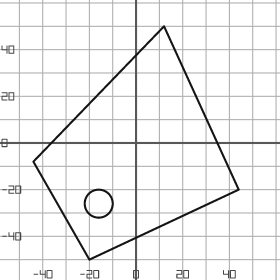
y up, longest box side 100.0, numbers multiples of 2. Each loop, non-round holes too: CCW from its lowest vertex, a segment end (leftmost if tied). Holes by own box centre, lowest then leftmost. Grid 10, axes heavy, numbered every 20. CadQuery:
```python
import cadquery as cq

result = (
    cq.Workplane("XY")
    .moveTo(-20.0, -50.0)
    .lineTo(44.0, -20.0)
    .lineTo(12.0, 50.0)
    .lineTo(-44.0, -8.0)
    .close()
    .moveTo(-16.0, -26.0)
    .circle(6.0)
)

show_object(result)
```